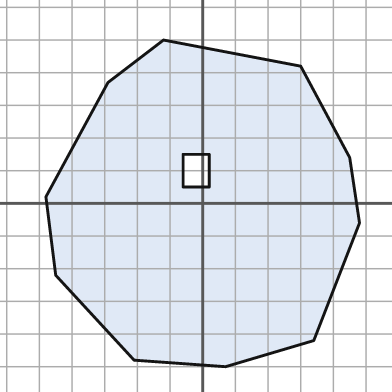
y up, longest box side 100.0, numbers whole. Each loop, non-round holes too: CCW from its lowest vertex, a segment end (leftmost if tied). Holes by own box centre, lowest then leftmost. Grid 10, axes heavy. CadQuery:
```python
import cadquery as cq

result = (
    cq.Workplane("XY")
    .moveTo(7.0, -50.0)
    .lineTo(34.0, -42.0)
    .lineTo(48.0, -6.0)
    .lineTo(45.0, 14.0)
    .lineTo(30.0, 42.0)
    .lineTo(-12.0, 50.0)
    .lineTo(-29.0, 37.0)
    .lineTo(-48.0, 2.0)
    .lineTo(-45.0, -22.0)
    .lineTo(-21.0, -48.0)
    .close()
    .moveTo(-6.0, 5.0)
    .lineTo(2.0, 5.0)
    .lineTo(2.0, 15.0)
    .lineTo(-6.0, 15.0)
    .close()
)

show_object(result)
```